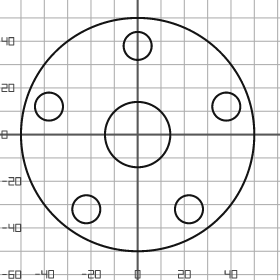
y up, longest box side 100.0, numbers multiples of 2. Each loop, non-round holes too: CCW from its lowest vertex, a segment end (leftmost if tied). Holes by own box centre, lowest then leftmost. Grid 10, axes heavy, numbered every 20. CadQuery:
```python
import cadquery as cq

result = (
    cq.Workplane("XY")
    .moveTo(0.0, 0.0)
    .circle(50.0)
    .moveTo(-22.0, -32.0)
    .circle(6.0)
    .moveTo(22.0, -32.0)
    .circle(6.0)
    .moveTo(0.0, 0.0)
    .circle(14.0)
    .moveTo(-38.0, 12.0)
    .circle(6.0)
    .moveTo(38.0, 12.0)
    .circle(6.0)
    .moveTo(0.0, 38.0)
    .circle(6.0)
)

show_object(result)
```